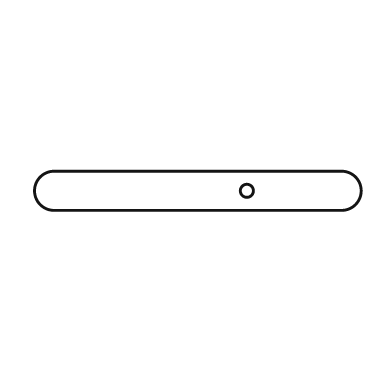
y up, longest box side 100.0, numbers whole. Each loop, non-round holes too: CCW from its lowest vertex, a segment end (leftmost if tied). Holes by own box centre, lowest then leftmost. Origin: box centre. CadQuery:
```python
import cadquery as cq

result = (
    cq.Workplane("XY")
    .moveTo(-44.0, -6.0)
    .lineTo(44.0, -6.0)
    .threePointArc((50.0, 0.0), (44.0, 6.0))
    .lineTo(-44.0, 6.0)
    .threePointArc((-50.0, 0.0), (-44.0, -6.0))
    .close()
    .moveTo(15.0, 0.0)
    .circle(2.0)
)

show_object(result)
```